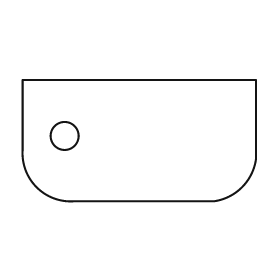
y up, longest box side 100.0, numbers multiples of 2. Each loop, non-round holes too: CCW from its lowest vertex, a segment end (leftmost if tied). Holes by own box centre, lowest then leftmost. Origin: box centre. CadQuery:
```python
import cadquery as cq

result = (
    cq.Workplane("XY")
    .moveTo(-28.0, -26.0)
    .lineTo(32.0, -26.0)
    .threePointArc((44.0, -20.0), (50.0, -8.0))
    .lineTo(50.0, 26.0)
    .lineTo(-50.0, 26.0)
    .lineTo(-50.0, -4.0)
    .threePointArc((-44.0, -20.0), (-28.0, -26.0))
    .close()
    .moveTo(-32.0, 2.0)
    .circle(6.0)
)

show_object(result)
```